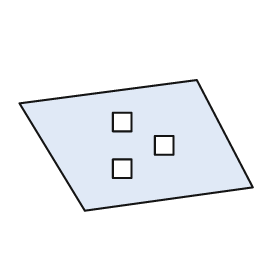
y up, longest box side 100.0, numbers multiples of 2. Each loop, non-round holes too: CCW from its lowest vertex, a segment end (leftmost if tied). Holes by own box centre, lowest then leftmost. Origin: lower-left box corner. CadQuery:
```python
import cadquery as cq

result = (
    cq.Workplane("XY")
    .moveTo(28.0, 0.0)
    .lineTo(100.0, 10.0)
    .lineTo(76.0, 56.0)
    .lineTo(0.0, 46.0)
    .close()
    .moveTo(40.0, 14.0)
    .lineTo(48.0, 14.0)
    .lineTo(48.0, 22.0)
    .lineTo(40.0, 22.0)
    .close()
    .moveTo(58.0, 24.0)
    .lineTo(66.0, 24.0)
    .lineTo(66.0, 32.0)
    .lineTo(58.0, 32.0)
    .close()
    .moveTo(40.0, 34.0)
    .lineTo(48.0, 34.0)
    .lineTo(48.0, 42.0)
    .lineTo(40.0, 42.0)
    .close()
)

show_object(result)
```